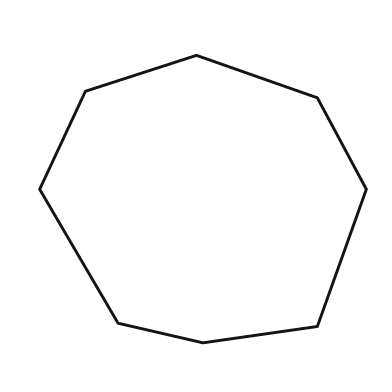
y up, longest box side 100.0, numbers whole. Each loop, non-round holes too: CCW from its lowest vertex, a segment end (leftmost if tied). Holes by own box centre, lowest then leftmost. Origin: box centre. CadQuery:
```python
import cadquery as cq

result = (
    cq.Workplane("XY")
    .moveTo(0.0, -44.0)
    .lineTo(35.0, -39.0)
    .lineTo(50.0, 3.0)
    .lineTo(35.0, 31.0)
    .lineTo(-2.0, 44.0)
    .lineTo(-36.0, 33.0)
    .lineTo(-50.0, 3.0)
    .lineTo(-26.0, -38.0)
    .close()
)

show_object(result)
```